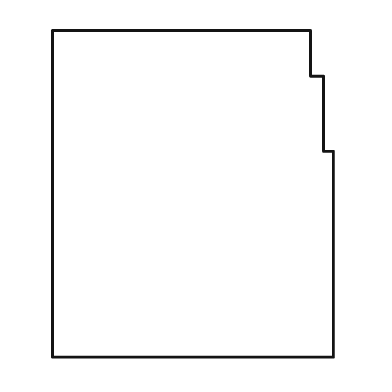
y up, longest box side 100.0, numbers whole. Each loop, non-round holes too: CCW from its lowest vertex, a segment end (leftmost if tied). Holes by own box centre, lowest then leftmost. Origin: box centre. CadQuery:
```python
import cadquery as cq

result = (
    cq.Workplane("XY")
    .moveTo(-43.0, -50.0)
    .lineTo(43.0, -50.0)
    .lineTo(43.0, 13.0)
    .lineTo(40.0, 13.0)
    .lineTo(40.0, 36.0)
    .lineTo(36.0, 36.0)
    .lineTo(36.0, 50.0)
    .lineTo(-43.0, 50.0)
    .close()
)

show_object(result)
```